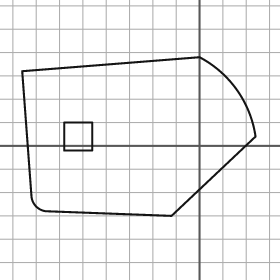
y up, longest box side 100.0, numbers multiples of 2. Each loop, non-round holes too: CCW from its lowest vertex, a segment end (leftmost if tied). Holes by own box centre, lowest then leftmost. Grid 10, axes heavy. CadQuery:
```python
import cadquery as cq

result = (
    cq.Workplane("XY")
    .moveTo(-12.0, -30.0)
    .lineTo(24.0, 4.0)
    .threePointArc((16.0, 24.0), (0.0, 38.0))
    .lineTo(-76.0, 32.0)
    .lineTo(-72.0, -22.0)
    .threePointArc((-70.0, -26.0), (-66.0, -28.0))
    .close()
    .moveTo(-58.0, -2.0)
    .lineTo(-46.0, -2.0)
    .lineTo(-46.0, 10.0)
    .lineTo(-58.0, 10.0)
    .close()
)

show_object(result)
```